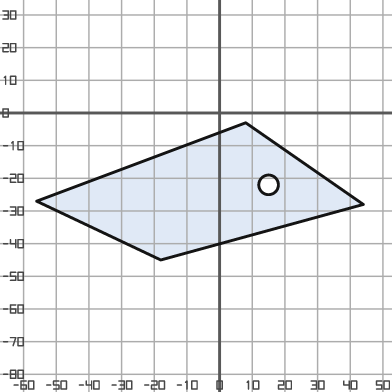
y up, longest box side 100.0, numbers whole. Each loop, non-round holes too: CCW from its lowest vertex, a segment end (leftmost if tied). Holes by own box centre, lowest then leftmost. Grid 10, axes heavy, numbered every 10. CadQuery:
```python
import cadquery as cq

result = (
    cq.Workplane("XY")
    .moveTo(-18.0, -45.0)
    .lineTo(44.0, -28.0)
    .lineTo(8.0, -3.0)
    .lineTo(-56.0, -27.0)
    .close()
    .moveTo(15.0, -22.0)
    .circle(3.0)
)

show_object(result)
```